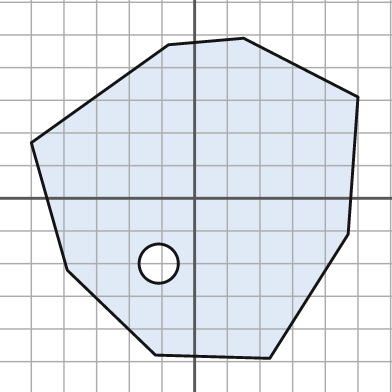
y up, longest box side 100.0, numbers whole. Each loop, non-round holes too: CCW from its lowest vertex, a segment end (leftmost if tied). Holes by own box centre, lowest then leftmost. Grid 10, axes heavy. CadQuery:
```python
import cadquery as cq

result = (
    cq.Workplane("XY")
    .moveTo(23.0, -49.0)
    .lineTo(47.0, -11.0)
    .lineTo(50.0, 31.0)
    .lineTo(15.0, 49.0)
    .lineTo(-8.0, 47.0)
    .lineTo(-50.0, 17.0)
    .lineTo(-39.0, -22.0)
    .lineTo(-12.0, -48.0)
    .close()
    .moveTo(-11.0, -20.0)
    .circle(6.0)
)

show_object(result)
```